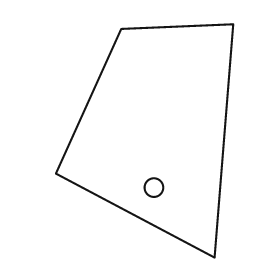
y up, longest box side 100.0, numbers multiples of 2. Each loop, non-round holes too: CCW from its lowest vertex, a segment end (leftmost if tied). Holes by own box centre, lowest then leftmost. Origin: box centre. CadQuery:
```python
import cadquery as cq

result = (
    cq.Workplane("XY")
    .moveTo(30.0, -50.0)
    .lineTo(38.0, 50.0)
    .lineTo(-10.0, 48.0)
    .lineTo(-38.0, -14.0)
    .close()
    .moveTo(4.0, -20.0)
    .circle(4.0)
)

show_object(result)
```